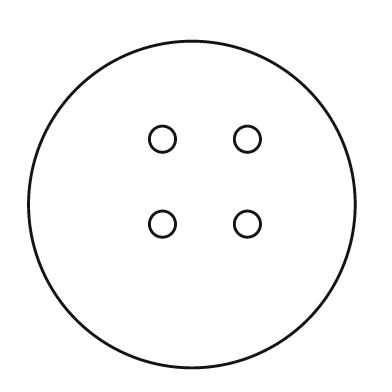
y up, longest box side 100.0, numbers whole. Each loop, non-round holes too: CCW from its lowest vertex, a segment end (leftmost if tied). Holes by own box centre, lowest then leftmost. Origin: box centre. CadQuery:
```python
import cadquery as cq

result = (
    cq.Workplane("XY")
    .moveTo(0.0, 0.0)
    .circle(50.0)
    .moveTo(-9.0, -6.0)
    .circle(4.0)
    .moveTo(17.0, -6.0)
    .circle(4.0)
    .moveTo(-9.0, 20.0)
    .circle(4.0)
    .moveTo(17.0, 20.0)
    .circle(4.0)
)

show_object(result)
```